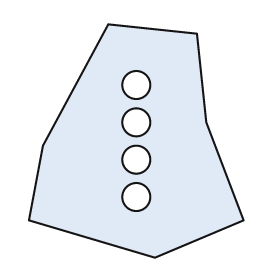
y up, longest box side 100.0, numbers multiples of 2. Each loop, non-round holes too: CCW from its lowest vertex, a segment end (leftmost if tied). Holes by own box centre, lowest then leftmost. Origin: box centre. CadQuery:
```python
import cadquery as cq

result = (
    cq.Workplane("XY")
    .moveTo(8.0, -50.0)
    .lineTo(46.0, -34.0)
    .lineTo(30.0, 8.0)
    .lineTo(26.0, 46.0)
    .lineTo(-12.0, 50.0)
    .lineTo(-40.0, -2.0)
    .lineTo(-46.0, -34.0)
    .close()
    .moveTo(0.0, -24.0)
    .circle(6.0)
    .moveTo(0.0, -8.0)
    .circle(6.0)
    .moveTo(0.0, 8.0)
    .circle(6.0)
    .moveTo(0.0, 24.0)
    .circle(6.0)
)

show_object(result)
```